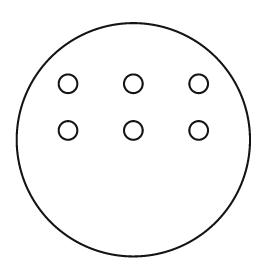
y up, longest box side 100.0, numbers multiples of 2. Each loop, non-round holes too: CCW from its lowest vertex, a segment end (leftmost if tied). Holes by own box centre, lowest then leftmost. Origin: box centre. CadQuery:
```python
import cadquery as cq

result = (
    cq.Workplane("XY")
    .moveTo(0.0, 0.0)
    .circle(50.0)
    .moveTo(-28.0, 4.0)
    .circle(4.0)
    .moveTo(0.0, 4.0)
    .circle(4.0)
    .moveTo(28.0, 4.0)
    .circle(4.0)
    .moveTo(-28.0, 24.0)
    .circle(4.0)
    .moveTo(0.0, 24.0)
    .circle(4.0)
    .moveTo(28.0, 24.0)
    .circle(4.0)
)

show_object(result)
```